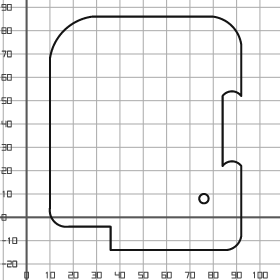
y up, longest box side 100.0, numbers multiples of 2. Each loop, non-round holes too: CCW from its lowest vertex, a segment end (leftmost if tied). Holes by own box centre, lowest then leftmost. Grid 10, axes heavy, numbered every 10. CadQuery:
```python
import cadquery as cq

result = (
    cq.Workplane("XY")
    .moveTo(36.0, -14.0)
    .lineTo(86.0, -14.0)
    .threePointArc((90.0, -12.0), (92.0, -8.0))
    .lineTo(92.0, 22.0)
    .threePointArc((88.0, 24.0), (84.0, 22.0))
    .lineTo(84.0, 52.0)
    .threePointArc((88.0, 54.0), (92.0, 52.0))
    .lineTo(92.0, 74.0)
    .threePointArc((88.0, 82.0), (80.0, 86.0))
    .lineTo(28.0, 86.0)
    .threePointArc((16.0, 80.0), (10.0, 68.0))
    .lineTo(10.0, 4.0)
    .threePointArc((12.0, -2.0), (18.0, -4.0))
    .lineTo(36.0, -4.0)
    .close()
    .moveTo(76.0, 8.0)
    .circle(2.0)
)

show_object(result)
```